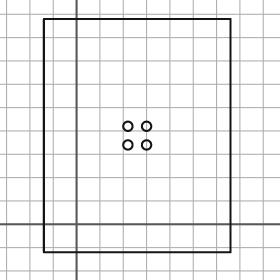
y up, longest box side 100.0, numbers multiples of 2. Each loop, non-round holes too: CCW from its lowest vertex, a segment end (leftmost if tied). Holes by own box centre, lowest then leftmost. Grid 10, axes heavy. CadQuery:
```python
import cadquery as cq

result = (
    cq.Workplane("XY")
    .moveTo(-14.0, -12.0)
    .lineTo(66.0, -12.0)
    .lineTo(66.0, 88.0)
    .lineTo(-14.0, 88.0)
    .close()
    .moveTo(22.0, 34.0)
    .circle(2.0)
    .moveTo(30.0, 34.0)
    .circle(2.0)
    .moveTo(22.0, 42.0)
    .circle(2.0)
    .moveTo(30.0, 42.0)
    .circle(2.0)
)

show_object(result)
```